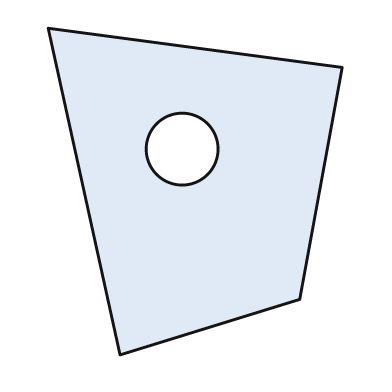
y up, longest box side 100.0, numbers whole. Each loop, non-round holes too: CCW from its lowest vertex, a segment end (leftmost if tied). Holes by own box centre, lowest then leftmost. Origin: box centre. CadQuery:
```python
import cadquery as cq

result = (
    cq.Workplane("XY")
    .moveTo(-23.0, -50.0)
    .lineTo(32.0, -33.0)
    .lineTo(45.0, 38.0)
    .lineTo(-45.0, 50.0)
    .close()
    .moveTo(-4.0, 13.0)
    .circle(11.0)
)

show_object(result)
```